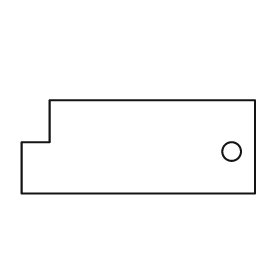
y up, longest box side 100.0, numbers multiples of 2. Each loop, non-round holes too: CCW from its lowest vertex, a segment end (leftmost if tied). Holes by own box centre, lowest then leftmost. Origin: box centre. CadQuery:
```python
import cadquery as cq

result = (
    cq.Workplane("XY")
    .moveTo(-50.0, -20.0)
    .lineTo(50.0, -20.0)
    .lineTo(50.0, 20.0)
    .lineTo(-38.0, 20.0)
    .lineTo(-38.0, 2.0)
    .lineTo(-50.0, 2.0)
    .close()
    .moveTo(40.0, -2.0)
    .circle(4.0)
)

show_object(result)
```